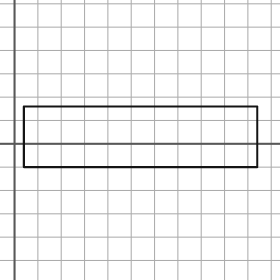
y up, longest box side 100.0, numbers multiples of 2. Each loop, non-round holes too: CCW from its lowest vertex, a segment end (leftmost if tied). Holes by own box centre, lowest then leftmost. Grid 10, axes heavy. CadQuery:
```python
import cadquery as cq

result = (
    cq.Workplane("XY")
    .moveTo(4.0, -10.0)
    .lineTo(104.0, -10.0)
    .lineTo(104.0, 16.0)
    .lineTo(4.0, 16.0)
    .close()
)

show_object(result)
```